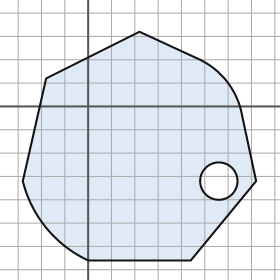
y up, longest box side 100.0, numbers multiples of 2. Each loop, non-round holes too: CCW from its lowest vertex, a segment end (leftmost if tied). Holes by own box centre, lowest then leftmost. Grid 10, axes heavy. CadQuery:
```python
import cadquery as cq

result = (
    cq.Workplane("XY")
    .moveTo(0.0, -66.0)
    .lineTo(44.0, -66.0)
    .lineTo(72.0, -32.0)
    .lineTo(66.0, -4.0)
    .threePointArc((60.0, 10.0), (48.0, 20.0))
    .lineTo(22.0, 32.0)
    .lineTo(-18.0, 12.0)
    .lineTo(-28.0, -32.0)
    .threePointArc((-18.0, -52.0), (0.0, -66.0))
    .close()
    .moveTo(56.0, -32.0)
    .circle(8.0)
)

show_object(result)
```